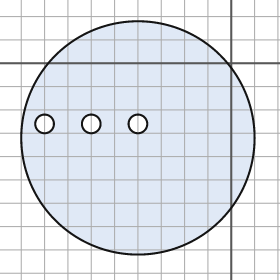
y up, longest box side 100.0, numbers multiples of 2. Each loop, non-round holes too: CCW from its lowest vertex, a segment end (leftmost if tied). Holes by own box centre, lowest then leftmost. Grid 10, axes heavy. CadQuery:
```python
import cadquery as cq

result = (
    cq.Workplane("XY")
    .moveTo(-40.0, -32.0)
    .circle(50.0)
    .moveTo(-80.0, -26.0)
    .circle(4.0)
    .moveTo(-60.0, -26.0)
    .circle(4.0)
    .moveTo(-40.0, -26.0)
    .circle(4.0)
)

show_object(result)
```